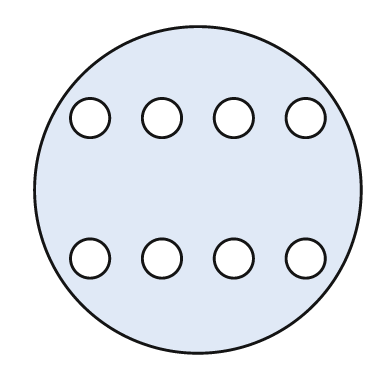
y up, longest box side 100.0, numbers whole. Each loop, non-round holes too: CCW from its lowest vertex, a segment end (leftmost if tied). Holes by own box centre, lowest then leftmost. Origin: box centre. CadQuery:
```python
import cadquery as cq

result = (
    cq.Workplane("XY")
    .moveTo(0.0, 0.0)
    .circle(50.0)
    .moveTo(-33.0, -21.0)
    .circle(6.0)
    .moveTo(-11.0, -21.0)
    .circle(6.0)
    .moveTo(11.0, -21.0)
    .circle(6.0)
    .moveTo(33.0, -21.0)
    .circle(6.0)
    .moveTo(-33.0, 22.0)
    .circle(6.0)
    .moveTo(-11.0, 22.0)
    .circle(6.0)
    .moveTo(11.0, 22.0)
    .circle(6.0)
    .moveTo(33.0, 22.0)
    .circle(6.0)
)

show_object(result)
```